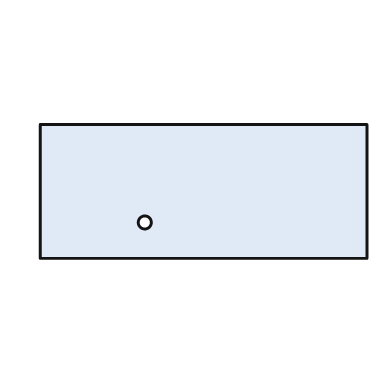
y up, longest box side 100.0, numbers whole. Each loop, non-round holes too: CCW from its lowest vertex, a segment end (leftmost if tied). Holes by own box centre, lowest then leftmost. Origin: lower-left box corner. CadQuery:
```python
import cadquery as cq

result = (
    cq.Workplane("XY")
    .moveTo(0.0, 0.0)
    .lineTo(100.0, 0.0)
    .lineTo(100.0, 41.0)
    .lineTo(0.0, 41.0)
    .close()
    .moveTo(32.0, 11.0)
    .circle(2.0)
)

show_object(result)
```